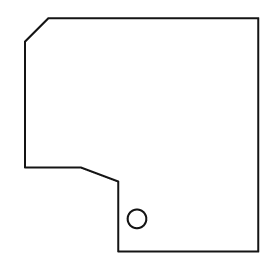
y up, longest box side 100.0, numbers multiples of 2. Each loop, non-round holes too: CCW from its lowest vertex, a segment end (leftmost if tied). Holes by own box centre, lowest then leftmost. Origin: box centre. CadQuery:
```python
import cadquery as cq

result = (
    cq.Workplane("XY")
    .moveTo(-10.0, -50.0)
    .lineTo(50.0, -50.0)
    .lineTo(50.0, 50.0)
    .lineTo(-40.0, 50.0)
    .lineTo(-50.0, 40.0)
    .lineTo(-50.0, -14.0)
    .lineTo(-26.0, -14.0)
    .lineTo(-10.0, -20.0)
    .close()
    .moveTo(-2.0, -36.0)
    .circle(4.0)
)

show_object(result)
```